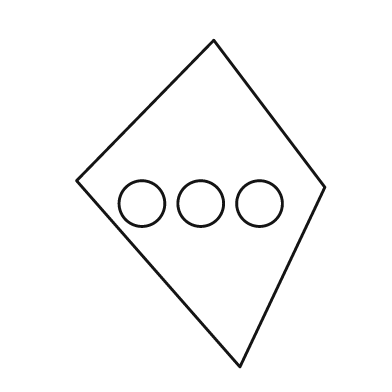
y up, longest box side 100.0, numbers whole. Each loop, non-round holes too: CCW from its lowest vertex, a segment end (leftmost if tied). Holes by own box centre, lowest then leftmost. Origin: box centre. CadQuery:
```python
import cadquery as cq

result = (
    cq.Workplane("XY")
    .moveTo(12.0, -50.0)
    .lineTo(38.0, 5.0)
    .lineTo(4.0, 50.0)
    .lineTo(-38.0, 7.0)
    .close()
    .moveTo(-18.0, 0.0)
    .circle(7.0)
    .moveTo(0.0, 0.0)
    .circle(7.0)
    .moveTo(18.0, 0.0)
    .circle(7.0)
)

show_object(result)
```